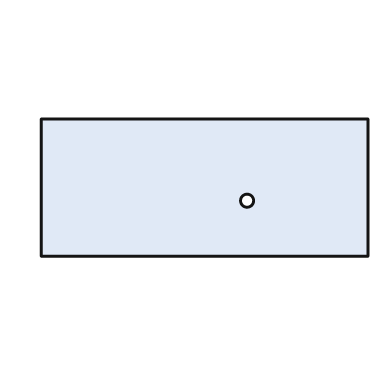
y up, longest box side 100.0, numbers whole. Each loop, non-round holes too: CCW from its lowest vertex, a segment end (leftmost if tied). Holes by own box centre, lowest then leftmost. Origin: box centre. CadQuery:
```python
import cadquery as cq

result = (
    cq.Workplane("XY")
    .moveTo(-50.0, -21.0)
    .lineTo(50.0, -21.0)
    .lineTo(50.0, 21.0)
    .lineTo(-50.0, 21.0)
    .close()
    .moveTo(13.0, -4.0)
    .circle(2.0)
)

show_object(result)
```